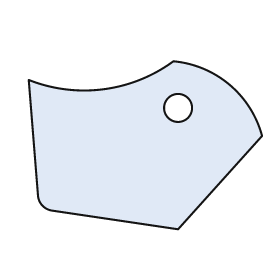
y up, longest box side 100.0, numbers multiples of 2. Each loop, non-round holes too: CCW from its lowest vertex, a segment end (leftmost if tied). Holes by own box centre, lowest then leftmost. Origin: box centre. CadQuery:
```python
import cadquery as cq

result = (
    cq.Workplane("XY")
    .moveTo(14.0, -36.0)
    .lineTo(50.0, 4.0)
    .threePointArc((36.0, 26.0), (12.0, 36.0))
    .threePointArc((-18.0, 24.0), (-50.0, 28.0))
    .lineTo(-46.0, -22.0)
    .threePointArc((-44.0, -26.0), (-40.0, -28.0))
    .close()
    .moveTo(14.0, 16.0)
    .circle(6.0)
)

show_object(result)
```